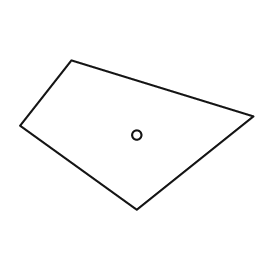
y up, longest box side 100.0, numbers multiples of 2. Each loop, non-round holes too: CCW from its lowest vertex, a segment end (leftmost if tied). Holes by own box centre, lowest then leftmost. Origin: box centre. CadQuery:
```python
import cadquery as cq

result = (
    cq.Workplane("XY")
    .moveTo(0.0, -32.0)
    .lineTo(50.0, 8.0)
    .lineTo(-28.0, 32.0)
    .lineTo(-50.0, 4.0)
    .close()
    .moveTo(0.0, 0.0)
    .circle(2.0)
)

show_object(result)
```